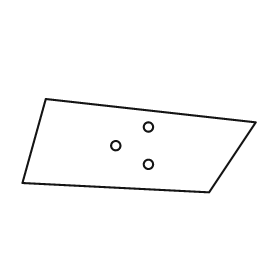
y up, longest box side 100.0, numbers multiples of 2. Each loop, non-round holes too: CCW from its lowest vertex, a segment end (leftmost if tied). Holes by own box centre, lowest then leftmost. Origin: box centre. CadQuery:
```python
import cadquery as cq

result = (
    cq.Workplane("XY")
    .moveTo(30.0, -20.0)
    .lineTo(50.0, 10.0)
    .lineTo(-40.0, 20.0)
    .lineTo(-50.0, -16.0)
    .close()
    .moveTo(4.0, -8.0)
    .circle(2.0)
    .moveTo(-10.0, 0.0)
    .circle(2.0)
    .moveTo(4.0, 8.0)
    .circle(2.0)
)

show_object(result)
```